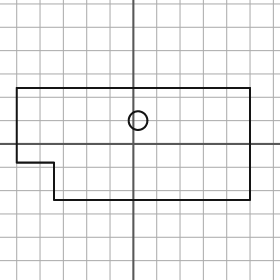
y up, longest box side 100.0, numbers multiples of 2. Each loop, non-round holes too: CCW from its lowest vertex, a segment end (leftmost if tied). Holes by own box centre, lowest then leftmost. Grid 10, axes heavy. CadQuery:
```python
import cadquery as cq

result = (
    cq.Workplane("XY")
    .moveTo(-34.0, -24.0)
    .lineTo(50.0, -24.0)
    .lineTo(50.0, 24.0)
    .lineTo(-50.0, 24.0)
    .lineTo(-50.0, -8.0)
    .lineTo(-34.0, -8.0)
    .close()
    .moveTo(2.0, 10.0)
    .circle(4.0)
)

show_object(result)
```